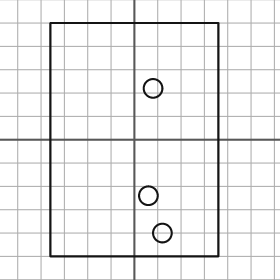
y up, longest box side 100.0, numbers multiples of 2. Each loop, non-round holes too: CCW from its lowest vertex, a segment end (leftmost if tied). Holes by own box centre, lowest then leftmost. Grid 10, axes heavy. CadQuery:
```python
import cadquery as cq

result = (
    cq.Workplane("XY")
    .moveTo(-36.0, -50.0)
    .lineTo(36.0, -50.0)
    .lineTo(36.0, 50.0)
    .lineTo(-36.0, 50.0)
    .close()
    .moveTo(12.0, -40.0)
    .circle(4.0)
    .moveTo(6.0, -24.0)
    .circle(4.0)
    .moveTo(8.0, 22.0)
    .circle(4.0)
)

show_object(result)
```